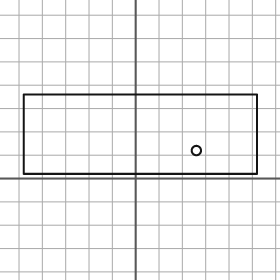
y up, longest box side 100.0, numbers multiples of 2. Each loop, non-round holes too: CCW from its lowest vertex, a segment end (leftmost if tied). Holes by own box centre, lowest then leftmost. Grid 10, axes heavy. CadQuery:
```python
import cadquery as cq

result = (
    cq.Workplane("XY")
    .moveTo(-48.0, 2.0)
    .lineTo(52.0, 2.0)
    .lineTo(52.0, 36.0)
    .lineTo(-48.0, 36.0)
    .close()
    .moveTo(26.0, 12.0)
    .circle(2.0)
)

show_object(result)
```